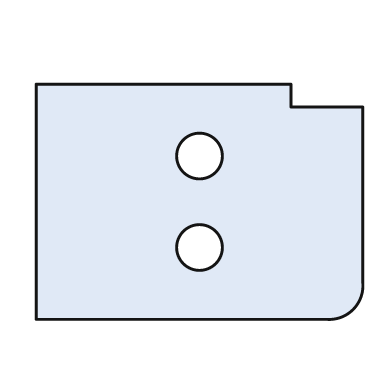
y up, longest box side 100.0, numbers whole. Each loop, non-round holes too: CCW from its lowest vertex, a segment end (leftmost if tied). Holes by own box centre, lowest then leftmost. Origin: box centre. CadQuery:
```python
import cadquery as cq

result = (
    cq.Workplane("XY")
    .moveTo(-50.0, -36.0)
    .lineTo(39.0, -36.0)
    .threePointArc((47.0, -33.0), (50.0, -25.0))
    .lineTo(50.0, 29.0)
    .lineTo(28.0, 29.0)
    .lineTo(28.0, 36.0)
    .lineTo(-50.0, 36.0)
    .close()
    .moveTo(0.0, -14.0)
    .circle(7.0)
    .moveTo(0.0, 14.0)
    .circle(7.0)
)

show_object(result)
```